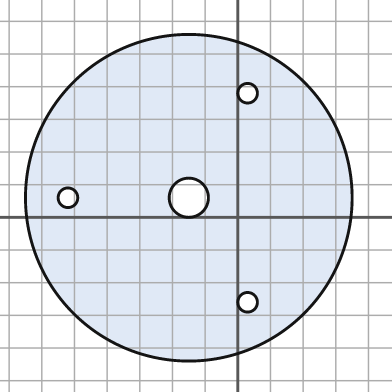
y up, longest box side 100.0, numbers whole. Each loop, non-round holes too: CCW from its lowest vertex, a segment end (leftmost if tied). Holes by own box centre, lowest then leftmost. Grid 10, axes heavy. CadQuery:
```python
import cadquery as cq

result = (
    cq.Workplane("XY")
    .moveTo(-15.0, 6.0)
    .circle(50.0)
    .moveTo(3.0, -26.0)
    .circle(3.0)
    .moveTo(-52.0, 6.0)
    .circle(3.0)
    .moveTo(-15.0, 6.0)
    .circle(6.0)
    .moveTo(3.0, 38.0)
    .circle(3.0)
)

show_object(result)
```